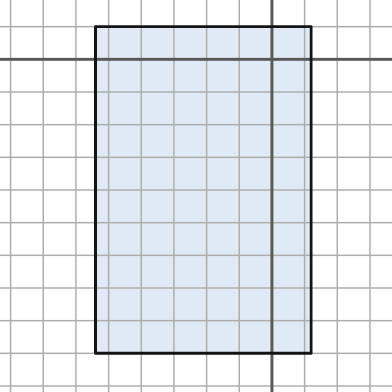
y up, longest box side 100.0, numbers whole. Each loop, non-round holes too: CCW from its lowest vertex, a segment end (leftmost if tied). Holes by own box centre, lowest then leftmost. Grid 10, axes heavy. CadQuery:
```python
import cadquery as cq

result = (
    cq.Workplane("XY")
    .moveTo(-54.0, -90.0)
    .lineTo(12.0, -90.0)
    .lineTo(12.0, 10.0)
    .lineTo(-54.0, 10.0)
    .close()
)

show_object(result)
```